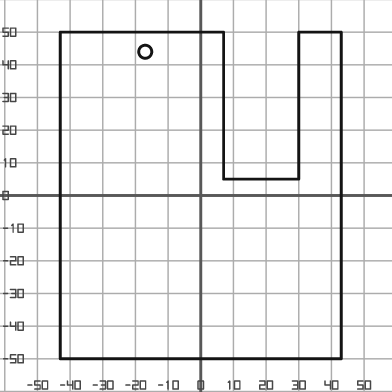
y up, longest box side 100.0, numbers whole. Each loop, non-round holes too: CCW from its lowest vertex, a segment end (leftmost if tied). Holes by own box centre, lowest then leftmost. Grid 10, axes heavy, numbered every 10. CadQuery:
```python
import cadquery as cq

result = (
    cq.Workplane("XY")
    .moveTo(-43.0, -50.0)
    .lineTo(43.0, -50.0)
    .lineTo(43.0, 50.0)
    .lineTo(30.0, 50.0)
    .lineTo(30.0, 5.0)
    .lineTo(7.0, 5.0)
    .lineTo(7.0, 50.0)
    .lineTo(-43.0, 50.0)
    .close()
    .moveTo(-17.0, 44.0)
    .circle(2.0)
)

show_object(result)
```